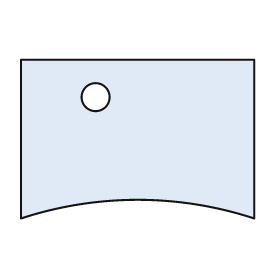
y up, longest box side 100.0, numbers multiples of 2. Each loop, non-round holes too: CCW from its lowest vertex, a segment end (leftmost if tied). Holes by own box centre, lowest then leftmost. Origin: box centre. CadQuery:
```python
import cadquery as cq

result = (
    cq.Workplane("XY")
    .moveTo(-50.0, -34.0)
    .threePointArc((0.0, -26.0), (50.0, -34.0))
    .lineTo(50.0, 34.0)
    .lineTo(-50.0, 34.0)
    .close()
    .moveTo(-18.0, 18.0)
    .circle(6.0)
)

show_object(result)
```